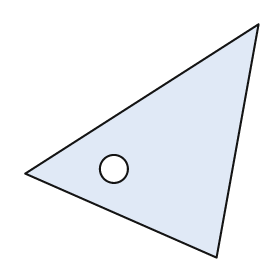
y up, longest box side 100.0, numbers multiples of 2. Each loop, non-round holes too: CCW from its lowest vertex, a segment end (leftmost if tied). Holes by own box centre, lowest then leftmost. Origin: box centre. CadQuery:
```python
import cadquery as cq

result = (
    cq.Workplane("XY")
    .moveTo(32.0, -50.0)
    .lineTo(50.0, 50.0)
    .lineTo(-50.0, -14.0)
    .close()
    .moveTo(-12.0, -12.0)
    .circle(6.0)
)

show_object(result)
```